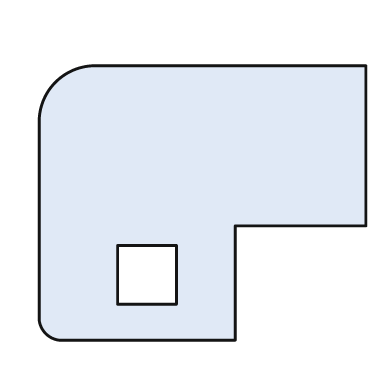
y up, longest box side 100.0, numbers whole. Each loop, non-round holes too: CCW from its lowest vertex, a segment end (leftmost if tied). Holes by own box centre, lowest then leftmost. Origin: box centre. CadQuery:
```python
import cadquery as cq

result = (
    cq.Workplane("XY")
    .moveTo(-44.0, -42.0)
    .lineTo(10.0, -42.0)
    .lineTo(10.0, -7.0)
    .lineTo(50.0, -7.0)
    .lineTo(50.0, 42.0)
    .lineTo(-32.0, 42.0)
    .threePointArc((-45.0, 37.0), (-50.0, 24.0))
    .lineTo(-50.0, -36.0)
    .threePointArc((-48.0, -40.0), (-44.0, -42.0))
    .close()
    .moveTo(-26.0, -31.0)
    .lineTo(-8.0, -31.0)
    .lineTo(-8.0, -13.0)
    .lineTo(-26.0, -13.0)
    .close()
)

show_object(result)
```